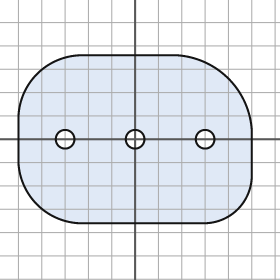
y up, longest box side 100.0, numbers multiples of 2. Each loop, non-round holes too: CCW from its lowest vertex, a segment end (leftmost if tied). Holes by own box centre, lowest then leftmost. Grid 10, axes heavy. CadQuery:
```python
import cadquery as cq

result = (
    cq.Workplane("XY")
    .moveTo(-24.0, -36.0)
    .lineTo(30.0, -36.0)
    .threePointArc((44.0, -30.0), (50.0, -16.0))
    .lineTo(50.0, 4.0)
    .threePointArc((40.0, 26.0), (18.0, 36.0))
    .lineTo(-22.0, 36.0)
    .threePointArc((-42.0, 28.0), (-50.0, 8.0))
    .lineTo(-50.0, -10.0)
    .threePointArc((-42.0, -28.0), (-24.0, -36.0))
    .close()
    .moveTo(-30.0, 0.0)
    .circle(4.0)
    .moveTo(0.0, 0.0)
    .circle(4.0)
    .moveTo(30.0, 0.0)
    .circle(4.0)
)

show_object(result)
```